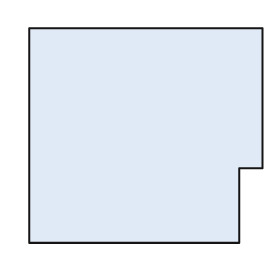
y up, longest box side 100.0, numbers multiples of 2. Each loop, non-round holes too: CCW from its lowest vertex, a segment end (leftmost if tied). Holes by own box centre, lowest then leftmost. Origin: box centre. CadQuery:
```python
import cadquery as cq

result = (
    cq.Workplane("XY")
    .moveTo(-50.0, -46.0)
    .lineTo(40.0, -46.0)
    .lineTo(40.0, -14.0)
    .lineTo(50.0, -14.0)
    .lineTo(50.0, 46.0)
    .lineTo(-50.0, 46.0)
    .close()
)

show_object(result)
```